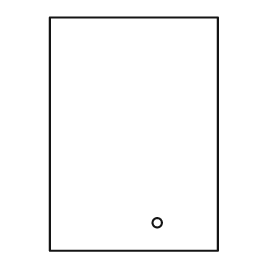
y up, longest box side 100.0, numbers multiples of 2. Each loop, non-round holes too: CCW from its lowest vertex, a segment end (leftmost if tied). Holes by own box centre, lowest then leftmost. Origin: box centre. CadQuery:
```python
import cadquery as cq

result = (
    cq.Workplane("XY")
    .moveTo(-36.0, -50.0)
    .lineTo(36.0, -50.0)
    .lineTo(36.0, 50.0)
    .lineTo(-36.0, 50.0)
    .close()
    .moveTo(10.0, -38.0)
    .circle(2.0)
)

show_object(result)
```